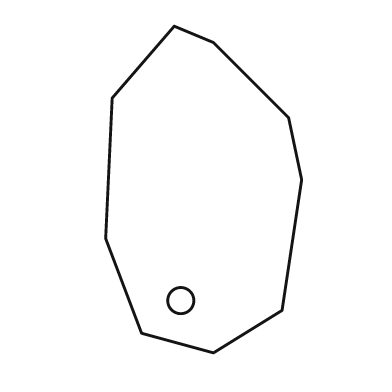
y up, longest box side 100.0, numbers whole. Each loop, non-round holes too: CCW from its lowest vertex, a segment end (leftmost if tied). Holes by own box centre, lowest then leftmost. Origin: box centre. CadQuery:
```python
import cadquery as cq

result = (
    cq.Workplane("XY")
    .moveTo(3.0, -50.0)
    .lineTo(24.0, -37.0)
    .lineTo(30.0, 3.0)
    .lineTo(26.0, 22.0)
    .lineTo(3.0, 45.0)
    .lineTo(-9.0, 50.0)
    .lineTo(-28.0, 28.0)
    .lineTo(-30.0, -15.0)
    .lineTo(-19.0, -44.0)
    .close()
    .moveTo(-7.0, -34.0)
    .circle(4.0)
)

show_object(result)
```